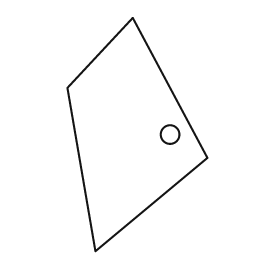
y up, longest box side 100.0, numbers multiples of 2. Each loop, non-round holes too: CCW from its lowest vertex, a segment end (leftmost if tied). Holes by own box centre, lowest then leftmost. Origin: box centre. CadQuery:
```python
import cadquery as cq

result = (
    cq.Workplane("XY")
    .moveTo(-18.0, -50.0)
    .lineTo(30.0, -10.0)
    .lineTo(-2.0, 50.0)
    .lineTo(-30.0, 20.0)
    .close()
    .moveTo(14.0, 0.0)
    .circle(4.0)
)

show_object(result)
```